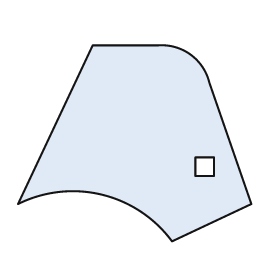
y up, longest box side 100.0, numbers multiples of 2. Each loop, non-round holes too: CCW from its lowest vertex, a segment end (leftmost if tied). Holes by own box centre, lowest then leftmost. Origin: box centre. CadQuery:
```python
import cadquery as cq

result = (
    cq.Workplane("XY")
    .moveTo(16.0, -42.0)
    .lineTo(50.0, -26.0)
    .lineTo(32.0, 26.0)
    .threePointArc((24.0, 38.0), (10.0, 42.0))
    .lineTo(-18.0, 42.0)
    .lineTo(-50.0, -26.0)
    .threePointArc((-14.0, -22.0), (16.0, -42.0))
    .close()
    .moveTo(26.0, -14.0)
    .lineTo(34.0, -14.0)
    .lineTo(34.0, -6.0)
    .lineTo(26.0, -6.0)
    .close()
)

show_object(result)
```